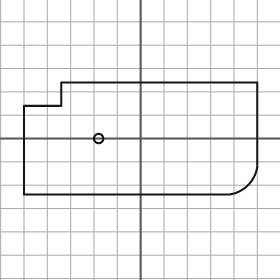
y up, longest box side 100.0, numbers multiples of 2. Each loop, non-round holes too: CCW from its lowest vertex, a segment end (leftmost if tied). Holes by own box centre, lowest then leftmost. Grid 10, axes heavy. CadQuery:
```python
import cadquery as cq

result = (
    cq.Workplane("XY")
    .moveTo(-50.0, -24.0)
    .lineTo(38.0, -24.0)
    .threePointArc((46.0, -20.0), (50.0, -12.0))
    .lineTo(50.0, 24.0)
    .lineTo(-34.0, 24.0)
    .lineTo(-34.0, 14.0)
    .lineTo(-50.0, 14.0)
    .close()
    .moveTo(-18.0, 0.0)
    .circle(2.0)
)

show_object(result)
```